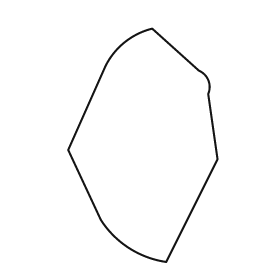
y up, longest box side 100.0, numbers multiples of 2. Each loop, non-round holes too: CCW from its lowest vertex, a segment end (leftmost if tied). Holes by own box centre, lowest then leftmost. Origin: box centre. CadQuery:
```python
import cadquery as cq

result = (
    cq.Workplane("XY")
    .moveTo(10.0, -50.0)
    .lineTo(32.0, -6.0)
    .lineTo(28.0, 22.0)
    .threePointArc((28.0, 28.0), (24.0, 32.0))
    .lineTo(4.0, 50.0)
    .threePointArc((-8.0, 44.0), (-16.0, 34.0))
    .lineTo(-32.0, -2.0)
    .lineTo(-18.0, -32.0)
    .threePointArc((-6.0, -44.0), (10.0, -50.0))
    .close()
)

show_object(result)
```